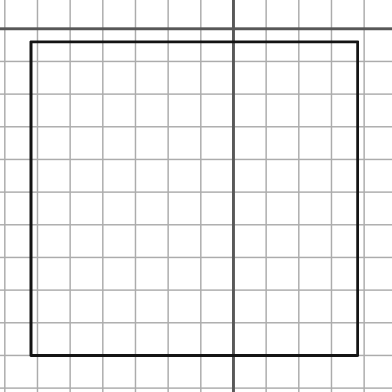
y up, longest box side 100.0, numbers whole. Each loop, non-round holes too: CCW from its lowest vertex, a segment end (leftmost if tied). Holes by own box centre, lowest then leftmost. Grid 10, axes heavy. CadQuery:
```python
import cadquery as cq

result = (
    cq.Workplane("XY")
    .moveTo(-62.0, -100.0)
    .lineTo(38.0, -100.0)
    .lineTo(38.0, -4.0)
    .lineTo(-62.0, -4.0)
    .close()
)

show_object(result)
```